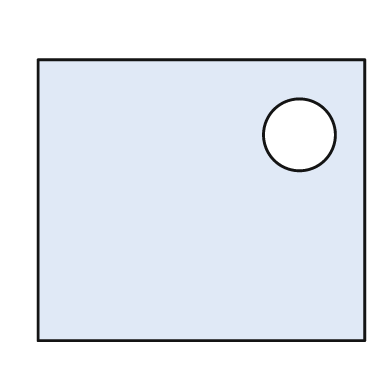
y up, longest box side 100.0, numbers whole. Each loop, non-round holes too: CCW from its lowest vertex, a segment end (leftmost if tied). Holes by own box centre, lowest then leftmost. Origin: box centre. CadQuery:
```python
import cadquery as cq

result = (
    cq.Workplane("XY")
    .moveTo(-50.0, -43.0)
    .lineTo(50.0, -43.0)
    .lineTo(50.0, 43.0)
    .lineTo(-50.0, 43.0)
    .close()
    .moveTo(30.0, 20.0)
    .circle(11.0)
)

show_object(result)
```